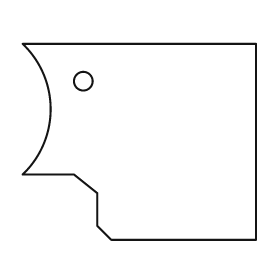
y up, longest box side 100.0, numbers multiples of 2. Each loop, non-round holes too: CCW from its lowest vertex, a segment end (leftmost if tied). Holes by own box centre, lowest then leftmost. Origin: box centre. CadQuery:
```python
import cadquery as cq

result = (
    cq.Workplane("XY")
    .moveTo(-12.0, -42.0)
    .lineTo(50.0, -42.0)
    .lineTo(50.0, 42.0)
    .lineTo(-50.0, 42.0)
    .threePointArc((-38.0, 14.0), (-50.0, -14.0))
    .lineTo(-28.0, -14.0)
    .lineTo(-18.0, -22.0)
    .lineTo(-18.0, -36.0)
    .close()
    .moveTo(-24.0, 26.0)
    .circle(4.0)
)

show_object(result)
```